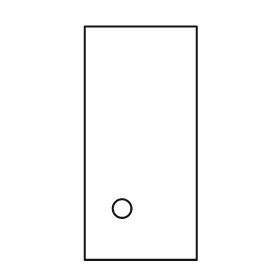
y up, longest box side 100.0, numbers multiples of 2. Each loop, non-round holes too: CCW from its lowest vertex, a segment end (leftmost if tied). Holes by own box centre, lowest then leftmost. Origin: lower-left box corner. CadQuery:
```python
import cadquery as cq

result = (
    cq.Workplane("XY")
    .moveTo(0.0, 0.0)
    .lineTo(48.0, 0.0)
    .lineTo(48.0, 100.0)
    .lineTo(0.0, 100.0)
    .close()
    .moveTo(16.0, 22.0)
    .circle(4.0)
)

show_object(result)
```